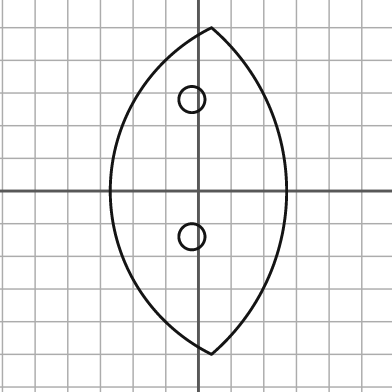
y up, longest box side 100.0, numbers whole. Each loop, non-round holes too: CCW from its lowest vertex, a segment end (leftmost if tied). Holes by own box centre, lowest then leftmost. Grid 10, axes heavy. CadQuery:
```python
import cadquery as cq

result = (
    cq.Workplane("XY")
    .moveTo(4.0, -50.0)
    .threePointArc((27.0, 0.0), (4.0, 50.0))
    .threePointArc((-27.0, 0.0), (4.0, -50.0))
    .close()
    .moveTo(-2.0, -14.0)
    .circle(4.0)
    .moveTo(-2.0, 28.0)
    .circle(4.0)
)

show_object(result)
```